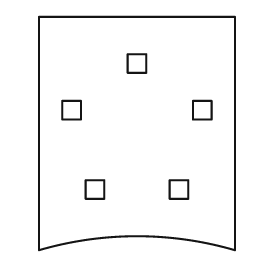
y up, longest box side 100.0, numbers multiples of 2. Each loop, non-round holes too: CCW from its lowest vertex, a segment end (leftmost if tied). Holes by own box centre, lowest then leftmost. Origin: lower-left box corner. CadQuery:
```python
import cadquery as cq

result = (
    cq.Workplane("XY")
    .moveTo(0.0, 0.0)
    .threePointArc((42.0, 6.0), (84.0, 0.0))
    .lineTo(84.0, 100.0)
    .lineTo(0.0, 100.0)
    .close()
    .moveTo(20.0, 22.0)
    .lineTo(28.0, 22.0)
    .lineTo(28.0, 30.0)
    .lineTo(20.0, 30.0)
    .close()
    .moveTo(56.0, 22.0)
    .lineTo(64.0, 22.0)
    .lineTo(64.0, 30.0)
    .lineTo(56.0, 30.0)
    .close()
    .moveTo(10.0, 56.0)
    .lineTo(18.0, 56.0)
    .lineTo(18.0, 64.0)
    .lineTo(10.0, 64.0)
    .close()
    .moveTo(66.0, 56.0)
    .lineTo(74.0, 56.0)
    .lineTo(74.0, 64.0)
    .lineTo(66.0, 64.0)
    .close()
    .moveTo(38.0, 76.0)
    .lineTo(46.0, 76.0)
    .lineTo(46.0, 84.0)
    .lineTo(38.0, 84.0)
    .close()
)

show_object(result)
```